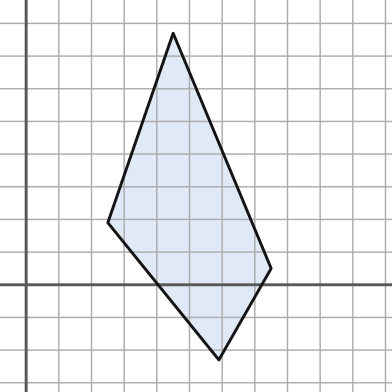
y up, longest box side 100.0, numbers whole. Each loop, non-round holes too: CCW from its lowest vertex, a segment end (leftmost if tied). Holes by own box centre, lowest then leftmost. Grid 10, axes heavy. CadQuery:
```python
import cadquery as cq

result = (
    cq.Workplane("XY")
    .moveTo(59.0, -23.0)
    .lineTo(75.0, 5.0)
    .lineTo(45.0, 77.0)
    .lineTo(25.0, 19.0)
    .close()
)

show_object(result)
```